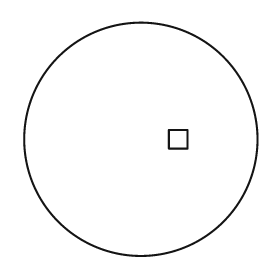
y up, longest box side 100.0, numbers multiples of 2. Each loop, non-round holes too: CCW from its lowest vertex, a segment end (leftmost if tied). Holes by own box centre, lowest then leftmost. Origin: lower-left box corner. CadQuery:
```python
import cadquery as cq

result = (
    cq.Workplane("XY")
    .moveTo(50.0, 50.0)
    .circle(50.0)
    .moveTo(62.0, 46.0)
    .lineTo(70.0, 46.0)
    .lineTo(70.0, 54.0)
    .lineTo(62.0, 54.0)
    .close()
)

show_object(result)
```